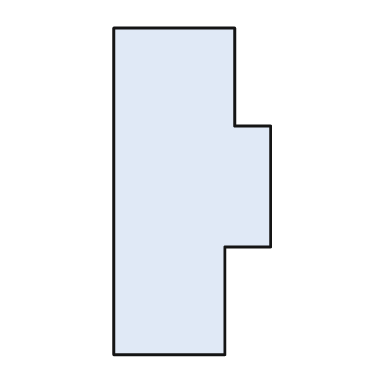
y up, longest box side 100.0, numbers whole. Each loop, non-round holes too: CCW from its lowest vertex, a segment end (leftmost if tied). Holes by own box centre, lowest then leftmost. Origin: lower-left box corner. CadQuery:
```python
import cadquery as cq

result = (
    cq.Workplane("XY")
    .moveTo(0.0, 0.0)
    .lineTo(34.0, 0.0)
    .lineTo(34.0, 33.0)
    .lineTo(48.0, 33.0)
    .lineTo(48.0, 70.0)
    .lineTo(37.0, 70.0)
    .lineTo(37.0, 100.0)
    .lineTo(0.0, 100.0)
    .close()
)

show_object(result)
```